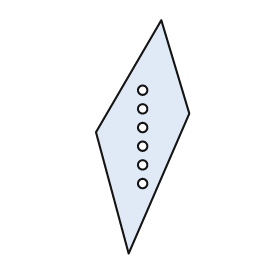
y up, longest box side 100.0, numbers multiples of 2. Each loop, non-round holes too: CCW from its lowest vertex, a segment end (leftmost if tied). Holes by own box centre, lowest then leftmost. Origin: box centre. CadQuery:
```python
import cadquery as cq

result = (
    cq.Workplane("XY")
    .moveTo(-6.0, -50.0)
    .lineTo(20.0, 10.0)
    .lineTo(8.0, 50.0)
    .lineTo(-20.0, 2.0)
    .close()
    .moveTo(0.0, -20.0)
    .circle(2.0)
    .moveTo(0.0, -12.0)
    .circle(2.0)
    .moveTo(0.0, -4.0)
    .circle(2.0)
    .moveTo(0.0, 4.0)
    .circle(2.0)
    .moveTo(0.0, 12.0)
    .circle(2.0)
    .moveTo(0.0, 20.0)
    .circle(2.0)
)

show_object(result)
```